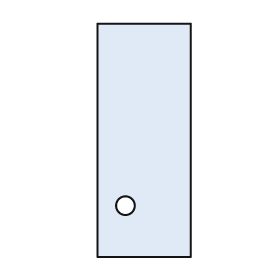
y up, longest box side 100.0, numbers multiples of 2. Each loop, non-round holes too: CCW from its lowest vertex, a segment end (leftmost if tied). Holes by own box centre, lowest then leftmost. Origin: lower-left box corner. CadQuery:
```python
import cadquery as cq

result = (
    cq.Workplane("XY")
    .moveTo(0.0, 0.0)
    .lineTo(40.0, 0.0)
    .lineTo(40.0, 100.0)
    .lineTo(0.0, 100.0)
    .close()
    .moveTo(12.0, 22.0)
    .circle(4.0)
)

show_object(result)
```